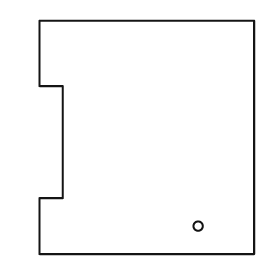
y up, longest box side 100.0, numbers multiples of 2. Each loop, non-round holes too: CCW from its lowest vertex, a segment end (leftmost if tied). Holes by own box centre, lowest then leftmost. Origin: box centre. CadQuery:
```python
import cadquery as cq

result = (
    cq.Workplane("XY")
    .moveTo(-46.0, -50.0)
    .lineTo(46.0, -50.0)
    .lineTo(46.0, 50.0)
    .lineTo(-46.0, 50.0)
    .lineTo(-46.0, 22.0)
    .lineTo(-36.0, 22.0)
    .lineTo(-36.0, -26.0)
    .lineTo(-46.0, -26.0)
    .close()
    .moveTo(22.0, -38.0)
    .circle(2.0)
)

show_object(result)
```